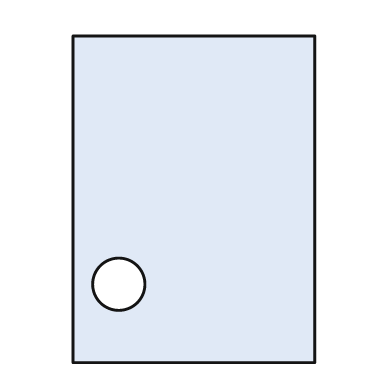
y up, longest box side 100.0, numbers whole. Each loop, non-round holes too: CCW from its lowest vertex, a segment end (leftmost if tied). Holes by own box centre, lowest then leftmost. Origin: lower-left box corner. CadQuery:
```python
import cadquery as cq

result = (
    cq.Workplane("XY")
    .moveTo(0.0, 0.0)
    .lineTo(74.0, 0.0)
    .lineTo(74.0, 100.0)
    .lineTo(0.0, 100.0)
    .close()
    .moveTo(14.0, 24.0)
    .circle(8.0)
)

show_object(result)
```